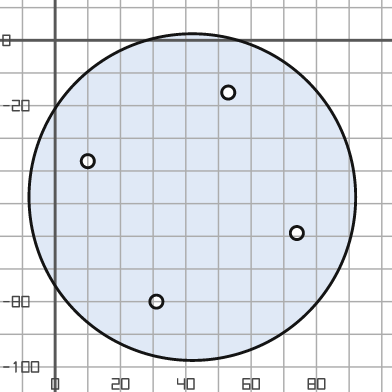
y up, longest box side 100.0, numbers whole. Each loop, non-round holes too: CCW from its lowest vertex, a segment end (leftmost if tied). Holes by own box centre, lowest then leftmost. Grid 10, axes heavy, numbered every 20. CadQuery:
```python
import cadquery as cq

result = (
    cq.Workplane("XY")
    .moveTo(42.0, -48.0)
    .circle(50.0)
    .moveTo(31.0, -80.0)
    .circle(2.0)
    .moveTo(74.0, -59.0)
    .circle(2.0)
    .moveTo(10.0, -37.0)
    .circle(2.0)
    .moveTo(53.0, -16.0)
    .circle(2.0)
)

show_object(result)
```